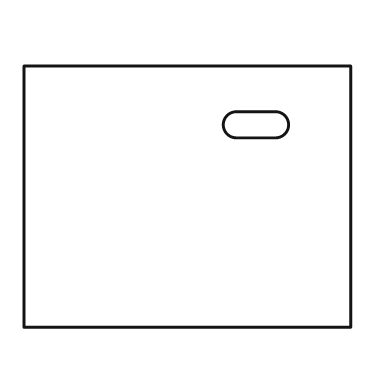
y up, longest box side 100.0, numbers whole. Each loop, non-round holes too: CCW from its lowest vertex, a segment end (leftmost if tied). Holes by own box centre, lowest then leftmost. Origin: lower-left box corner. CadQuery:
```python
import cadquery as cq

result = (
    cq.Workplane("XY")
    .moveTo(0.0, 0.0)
    .lineTo(100.0, 0.0)
    .lineTo(100.0, 80.0)
    .lineTo(0.0, 80.0)
    .close()
    .moveTo(65.0, 58.0)
    .lineTo(77.0, 58.0)
    .threePointArc((81.0, 62.0), (77.0, 66.0))
    .lineTo(65.0, 66.0)
    .threePointArc((61.0, 62.0), (65.0, 58.0))
    .close()
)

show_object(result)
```